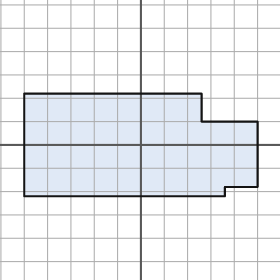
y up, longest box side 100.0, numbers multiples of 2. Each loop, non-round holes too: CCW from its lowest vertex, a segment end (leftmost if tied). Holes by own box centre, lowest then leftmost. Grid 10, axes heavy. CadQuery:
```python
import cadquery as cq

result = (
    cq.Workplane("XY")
    .moveTo(-50.0, -22.0)
    .lineTo(36.0, -22.0)
    .lineTo(36.0, -18.0)
    .lineTo(50.0, -18.0)
    .lineTo(50.0, 10.0)
    .lineTo(26.0, 10.0)
    .lineTo(26.0, 22.0)
    .lineTo(-50.0, 22.0)
    .close()
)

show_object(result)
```